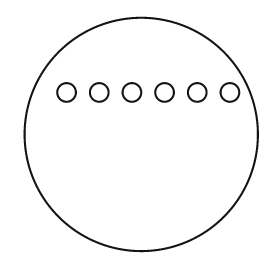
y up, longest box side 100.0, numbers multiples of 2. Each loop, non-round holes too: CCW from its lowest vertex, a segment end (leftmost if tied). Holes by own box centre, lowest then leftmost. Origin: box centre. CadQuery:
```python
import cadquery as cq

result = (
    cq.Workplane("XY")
    .moveTo(0.0, 0.0)
    .circle(50.0)
    .moveTo(-32.0, 18.0)
    .circle(4.0)
    .moveTo(-18.0, 18.0)
    .circle(4.0)
    .moveTo(-4.0, 18.0)
    .circle(4.0)
    .moveTo(10.0, 18.0)
    .circle(4.0)
    .moveTo(24.0, 18.0)
    .circle(4.0)
    .moveTo(38.0, 18.0)
    .circle(4.0)
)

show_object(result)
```